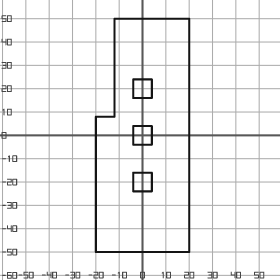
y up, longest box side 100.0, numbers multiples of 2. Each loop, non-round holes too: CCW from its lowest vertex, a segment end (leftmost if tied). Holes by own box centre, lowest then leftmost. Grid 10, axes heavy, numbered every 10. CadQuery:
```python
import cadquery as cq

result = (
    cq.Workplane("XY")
    .moveTo(-20.0, -50.0)
    .lineTo(20.0, -50.0)
    .lineTo(20.0, 50.0)
    .lineTo(-12.0, 50.0)
    .lineTo(-12.0, 8.0)
    .lineTo(-20.0, 8.0)
    .close()
    .moveTo(-4.0, -24.0)
    .lineTo(4.0, -24.0)
    .lineTo(4.0, -16.0)
    .lineTo(-4.0, -16.0)
    .close()
    .moveTo(-4.0, -4.0)
    .lineTo(4.0, -4.0)
    .lineTo(4.0, 4.0)
    .lineTo(-4.0, 4.0)
    .close()
    .moveTo(-4.0, 16.0)
    .lineTo(4.0, 16.0)
    .lineTo(4.0, 24.0)
    .lineTo(-4.0, 24.0)
    .close()
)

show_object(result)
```